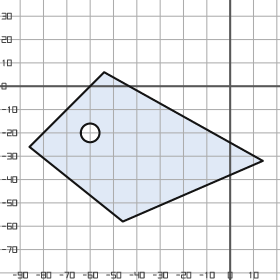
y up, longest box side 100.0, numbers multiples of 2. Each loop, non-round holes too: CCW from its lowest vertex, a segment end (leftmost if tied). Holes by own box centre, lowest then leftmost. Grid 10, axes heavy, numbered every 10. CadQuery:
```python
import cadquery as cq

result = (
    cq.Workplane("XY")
    .moveTo(-46.0, -58.0)
    .lineTo(14.0, -32.0)
    .lineTo(-54.0, 6.0)
    .lineTo(-86.0, -26.0)
    .close()
    .moveTo(-60.0, -20.0)
    .circle(4.0)
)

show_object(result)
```